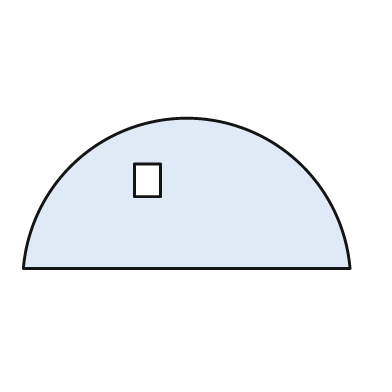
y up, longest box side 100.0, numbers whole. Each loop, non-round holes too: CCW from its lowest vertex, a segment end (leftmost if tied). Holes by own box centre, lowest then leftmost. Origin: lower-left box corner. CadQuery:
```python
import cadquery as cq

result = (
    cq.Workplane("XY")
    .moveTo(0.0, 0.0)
    .lineTo(100.0, 0.0)
    .threePointArc((50.0, 46.0), (0.0, 0.0))
    .close()
    .moveTo(34.0, 22.0)
    .lineTo(42.0, 22.0)
    .lineTo(42.0, 32.0)
    .lineTo(34.0, 32.0)
    .close()
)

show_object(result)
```